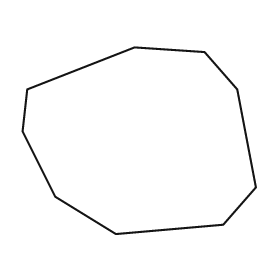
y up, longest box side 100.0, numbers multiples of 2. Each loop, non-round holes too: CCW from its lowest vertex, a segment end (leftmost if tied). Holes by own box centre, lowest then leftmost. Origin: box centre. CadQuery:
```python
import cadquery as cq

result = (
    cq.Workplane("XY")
    .moveTo(-10.0, -40.0)
    .lineTo(36.0, -36.0)
    .lineTo(50.0, -20.0)
    .lineTo(42.0, 22.0)
    .lineTo(28.0, 38.0)
    .lineTo(-2.0, 40.0)
    .lineTo(-48.0, 22.0)
    .lineTo(-50.0, 4.0)
    .lineTo(-36.0, -24.0)
    .close()
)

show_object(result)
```